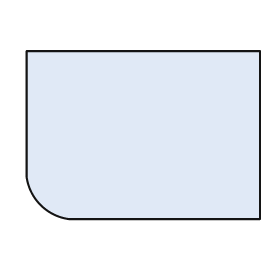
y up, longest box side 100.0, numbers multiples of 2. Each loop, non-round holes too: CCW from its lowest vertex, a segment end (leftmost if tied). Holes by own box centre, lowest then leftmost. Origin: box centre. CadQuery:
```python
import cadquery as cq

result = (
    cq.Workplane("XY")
    .moveTo(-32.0, -36.0)
    .lineTo(50.0, -36.0)
    .lineTo(50.0, 36.0)
    .lineTo(-50.0, 36.0)
    .lineTo(-50.0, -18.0)
    .threePointArc((-44.0, -30.0), (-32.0, -36.0))
    .close()
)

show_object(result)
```